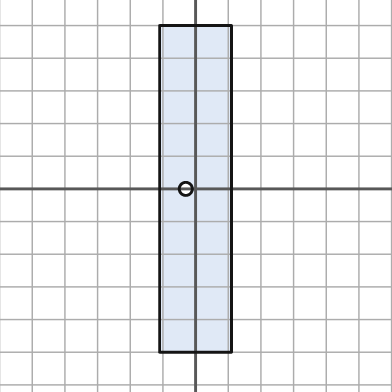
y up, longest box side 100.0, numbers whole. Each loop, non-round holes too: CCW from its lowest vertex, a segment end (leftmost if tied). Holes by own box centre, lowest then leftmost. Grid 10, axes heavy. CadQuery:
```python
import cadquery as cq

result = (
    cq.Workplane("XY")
    .moveTo(-11.0, -50.0)
    .lineTo(11.0, -50.0)
    .lineTo(11.0, 50.0)
    .lineTo(-11.0, 50.0)
    .close()
    .moveTo(-3.0, 0.0)
    .circle(2.0)
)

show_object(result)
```